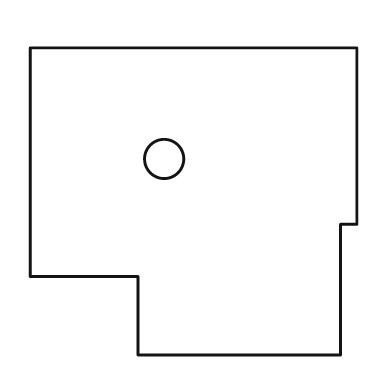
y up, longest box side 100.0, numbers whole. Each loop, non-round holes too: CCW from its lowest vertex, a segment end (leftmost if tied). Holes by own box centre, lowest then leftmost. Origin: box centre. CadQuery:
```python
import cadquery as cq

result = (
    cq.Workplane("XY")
    .moveTo(-17.0, -47.0)
    .lineTo(45.0, -47.0)
    .lineTo(45.0, -7.0)
    .lineTo(50.0, -7.0)
    .lineTo(50.0, 47.0)
    .lineTo(-50.0, 47.0)
    .lineTo(-50.0, -23.0)
    .lineTo(-17.0, -23.0)
    .close()
    .moveTo(-9.0, 13.0)
    .circle(6.0)
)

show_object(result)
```